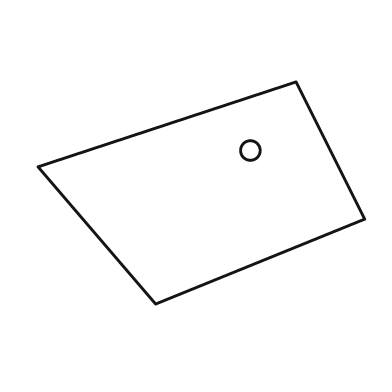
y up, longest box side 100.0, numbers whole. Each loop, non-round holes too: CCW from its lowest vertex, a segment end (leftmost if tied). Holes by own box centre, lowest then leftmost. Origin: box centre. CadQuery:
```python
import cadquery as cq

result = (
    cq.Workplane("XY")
    .moveTo(-14.0, -34.0)
    .lineTo(50.0, -8.0)
    .lineTo(29.0, 34.0)
    .lineTo(-50.0, 8.0)
    .close()
    .moveTo(15.0, 13.0)
    .circle(3.0)
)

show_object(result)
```